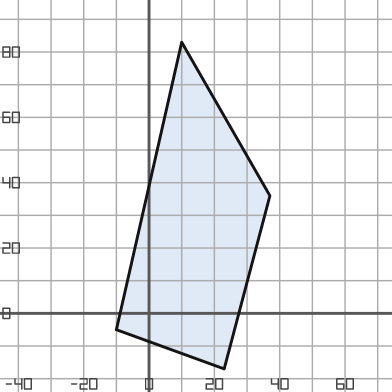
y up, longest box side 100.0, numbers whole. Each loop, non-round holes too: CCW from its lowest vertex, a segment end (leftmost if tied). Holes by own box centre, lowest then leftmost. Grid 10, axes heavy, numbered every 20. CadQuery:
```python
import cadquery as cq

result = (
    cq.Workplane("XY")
    .moveTo(23.0, -17.0)
    .lineTo(37.0, 36.0)
    .lineTo(10.0, 83.0)
    .lineTo(-10.0, -5.0)
    .close()
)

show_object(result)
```